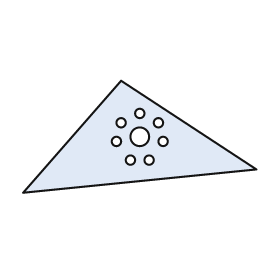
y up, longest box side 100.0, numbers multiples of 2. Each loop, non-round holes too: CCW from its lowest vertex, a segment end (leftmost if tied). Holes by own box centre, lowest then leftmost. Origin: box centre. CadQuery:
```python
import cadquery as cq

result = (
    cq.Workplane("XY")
    .moveTo(-50.0, -24.0)
    .lineTo(50.0, -14.0)
    .lineTo(-8.0, 24.0)
    .close()
    .moveTo(-4.0, -10.0)
    .circle(2.0)
    .moveTo(4.0, -10.0)
    .circle(2.0)
    .moveTo(-10.0, -2.0)
    .circle(2.0)
    .moveTo(10.0, -2.0)
    .circle(2.0)
    .moveTo(0.0, 0.0)
    .circle(4.0)
    .moveTo(-8.0, 6.0)
    .circle(2.0)
    .moveTo(8.0, 6.0)
    .circle(2.0)
    .moveTo(0.0, 10.0)
    .circle(2.0)
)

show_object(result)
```